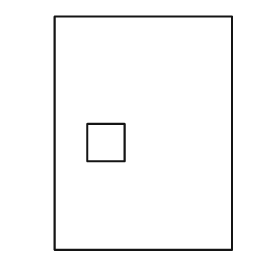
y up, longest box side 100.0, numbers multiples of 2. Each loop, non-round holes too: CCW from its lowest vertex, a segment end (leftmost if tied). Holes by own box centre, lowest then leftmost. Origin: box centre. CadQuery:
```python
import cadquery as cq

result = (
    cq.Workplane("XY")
    .moveTo(-38.0, -50.0)
    .lineTo(38.0, -50.0)
    .lineTo(38.0, 50.0)
    .lineTo(-38.0, 50.0)
    .close()
    .moveTo(-24.0, -12.0)
    .lineTo(-8.0, -12.0)
    .lineTo(-8.0, 4.0)
    .lineTo(-24.0, 4.0)
    .close()
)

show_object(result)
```